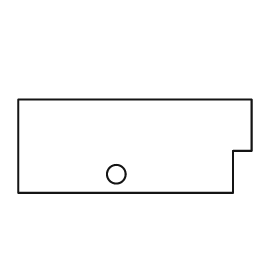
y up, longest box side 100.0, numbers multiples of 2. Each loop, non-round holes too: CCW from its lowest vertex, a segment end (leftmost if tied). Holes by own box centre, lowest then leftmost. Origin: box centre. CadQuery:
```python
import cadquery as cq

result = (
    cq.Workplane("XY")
    .moveTo(-50.0, -20.0)
    .lineTo(42.0, -20.0)
    .lineTo(42.0, -2.0)
    .lineTo(50.0, -2.0)
    .lineTo(50.0, 20.0)
    .lineTo(-50.0, 20.0)
    .close()
    .moveTo(-8.0, -12.0)
    .circle(4.0)
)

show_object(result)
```